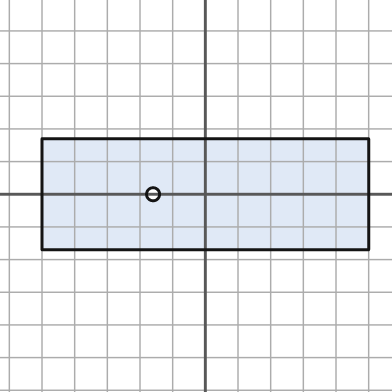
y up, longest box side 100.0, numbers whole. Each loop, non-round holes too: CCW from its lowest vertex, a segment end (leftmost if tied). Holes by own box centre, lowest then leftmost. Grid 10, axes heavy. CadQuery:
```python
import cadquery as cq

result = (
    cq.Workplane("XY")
    .moveTo(-50.0, -17.0)
    .lineTo(50.0, -17.0)
    .lineTo(50.0, 17.0)
    .lineTo(-50.0, 17.0)
    .close()
    .moveTo(-16.0, 0.0)
    .circle(2.0)
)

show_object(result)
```